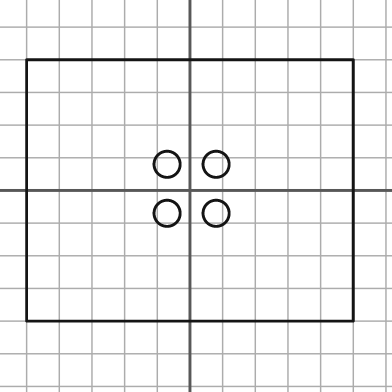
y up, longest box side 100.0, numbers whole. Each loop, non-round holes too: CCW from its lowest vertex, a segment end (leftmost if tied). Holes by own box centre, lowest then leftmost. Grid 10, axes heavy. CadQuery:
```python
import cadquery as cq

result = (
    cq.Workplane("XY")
    .moveTo(-50.0, -40.0)
    .lineTo(50.0, -40.0)
    .lineTo(50.0, 40.0)
    .lineTo(-50.0, 40.0)
    .close()
    .moveTo(-7.0, -7.0)
    .circle(4.0)
    .moveTo(8.0, -7.0)
    .circle(4.0)
    .moveTo(-7.0, 8.0)
    .circle(4.0)
    .moveTo(8.0, 8.0)
    .circle(4.0)
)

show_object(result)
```